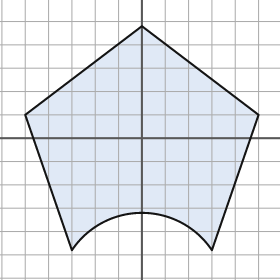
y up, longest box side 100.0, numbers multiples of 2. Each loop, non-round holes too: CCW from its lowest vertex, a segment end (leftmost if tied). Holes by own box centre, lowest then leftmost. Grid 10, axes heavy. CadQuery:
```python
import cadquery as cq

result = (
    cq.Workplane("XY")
    .moveTo(-30.0, -48.0)
    .threePointArc((0.0, -32.0), (30.0, -48.0))
    .lineTo(50.0, 10.0)
    .lineTo(0.0, 48.0)
    .lineTo(-50.0, 10.0)
    .close()
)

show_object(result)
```